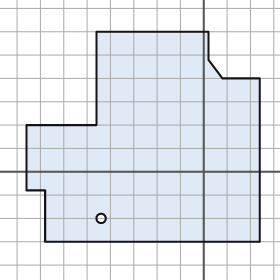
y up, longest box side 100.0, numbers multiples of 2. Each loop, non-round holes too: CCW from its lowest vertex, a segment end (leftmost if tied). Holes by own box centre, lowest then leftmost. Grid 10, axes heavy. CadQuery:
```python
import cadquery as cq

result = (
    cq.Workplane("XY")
    .moveTo(-68.0, -30.0)
    .lineTo(24.0, -30.0)
    .lineTo(24.0, 40.0)
    .lineTo(8.0, 40.0)
    .lineTo(2.0, 48.0)
    .lineTo(2.0, 60.0)
    .lineTo(-46.0, 60.0)
    .lineTo(-46.0, 20.0)
    .lineTo(-76.0, 20.0)
    .lineTo(-76.0, -8.0)
    .lineTo(-68.0, -8.0)
    .close()
    .moveTo(-44.0, -20.0)
    .circle(2.0)
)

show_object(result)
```